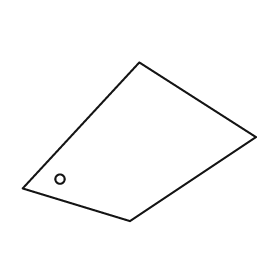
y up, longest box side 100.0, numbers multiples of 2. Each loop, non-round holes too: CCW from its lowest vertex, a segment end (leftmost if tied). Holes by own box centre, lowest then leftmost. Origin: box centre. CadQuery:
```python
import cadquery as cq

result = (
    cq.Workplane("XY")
    .moveTo(-4.0, -34.0)
    .lineTo(50.0, 2.0)
    .lineTo(0.0, 34.0)
    .lineTo(-50.0, -20.0)
    .close()
    .moveTo(-34.0, -16.0)
    .circle(2.0)
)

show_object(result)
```